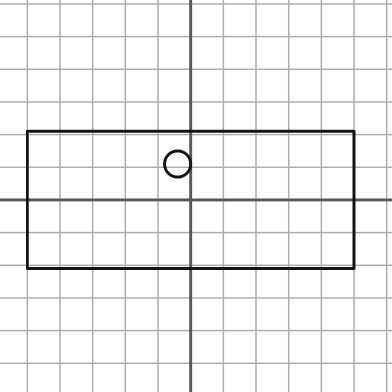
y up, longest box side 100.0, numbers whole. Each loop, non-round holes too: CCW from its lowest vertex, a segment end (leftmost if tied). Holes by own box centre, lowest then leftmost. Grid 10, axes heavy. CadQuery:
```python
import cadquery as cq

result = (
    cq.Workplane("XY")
    .moveTo(-50.0, -21.0)
    .lineTo(50.0, -21.0)
    .lineTo(50.0, 21.0)
    .lineTo(-50.0, 21.0)
    .close()
    .moveTo(-4.0, 11.0)
    .circle(4.0)
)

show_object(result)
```